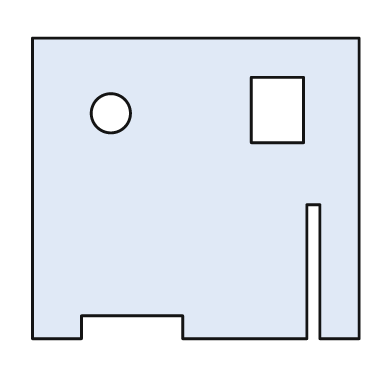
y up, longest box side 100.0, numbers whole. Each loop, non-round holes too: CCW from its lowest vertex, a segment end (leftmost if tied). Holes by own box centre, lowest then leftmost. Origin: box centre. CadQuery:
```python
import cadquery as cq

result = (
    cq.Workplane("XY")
    .moveTo(-50.0, -46.0)
    .lineTo(-35.0, -46.0)
    .lineTo(-35.0, -39.0)
    .lineTo(-4.0, -39.0)
    .lineTo(-4.0, -46.0)
    .lineTo(34.0, -46.0)
    .lineTo(34.0, -5.0)
    .lineTo(38.0, -5.0)
    .lineTo(38.0, -46.0)
    .lineTo(50.0, -46.0)
    .lineTo(50.0, 46.0)
    .lineTo(-50.0, 46.0)
    .close()
    .moveTo(-26.0, 23.0)
    .circle(6.0)
    .moveTo(17.0, 14.0)
    .lineTo(33.0, 14.0)
    .lineTo(33.0, 34.0)
    .lineTo(17.0, 34.0)
    .close()
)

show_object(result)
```